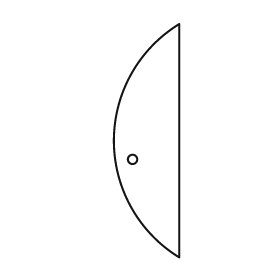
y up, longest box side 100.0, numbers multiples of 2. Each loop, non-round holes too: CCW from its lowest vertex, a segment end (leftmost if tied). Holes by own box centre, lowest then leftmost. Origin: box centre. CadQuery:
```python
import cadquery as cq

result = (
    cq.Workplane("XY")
    .moveTo(14.0, -50.0)
    .lineTo(14.0, 50.0)
    .threePointArc((-14.0, 0.0), (14.0, -50.0))
    .close()
    .moveTo(-6.0, -8.0)
    .circle(2.0)
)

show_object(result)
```